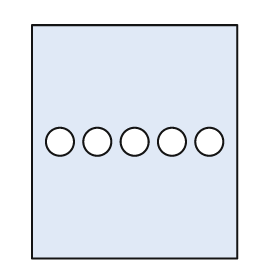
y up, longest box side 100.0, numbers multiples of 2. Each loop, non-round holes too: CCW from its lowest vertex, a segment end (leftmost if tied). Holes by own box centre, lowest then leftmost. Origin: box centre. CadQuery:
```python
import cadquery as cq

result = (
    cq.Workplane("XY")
    .moveTo(-44.0, -50.0)
    .lineTo(44.0, -50.0)
    .lineTo(44.0, 50.0)
    .lineTo(-44.0, 50.0)
    .close()
    .moveTo(-32.0, 0.0)
    .circle(6.0)
    .moveTo(-16.0, 0.0)
    .circle(6.0)
    .moveTo(0.0, 0.0)
    .circle(6.0)
    .moveTo(16.0, 0.0)
    .circle(6.0)
    .moveTo(32.0, 0.0)
    .circle(6.0)
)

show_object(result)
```